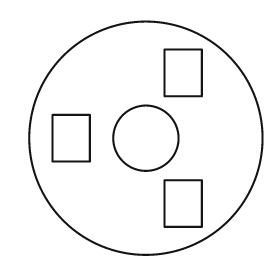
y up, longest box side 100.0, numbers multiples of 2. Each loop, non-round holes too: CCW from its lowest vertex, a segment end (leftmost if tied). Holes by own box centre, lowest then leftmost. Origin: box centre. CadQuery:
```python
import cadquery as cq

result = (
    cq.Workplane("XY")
    .moveTo(0.0, 0.0)
    .circle(50.0)
    .moveTo(8.0, -38.0)
    .lineTo(24.0, -38.0)
    .lineTo(24.0, -18.0)
    .lineTo(8.0, -18.0)
    .close()
    .moveTo(-40.0, -10.0)
    .lineTo(-24.0, -10.0)
    .lineTo(-24.0, 10.0)
    .lineTo(-40.0, 10.0)
    .close()
    .moveTo(0.0, 0.0)
    .circle(14.0)
    .moveTo(8.0, 18.0)
    .lineTo(24.0, 18.0)
    .lineTo(24.0, 38.0)
    .lineTo(8.0, 38.0)
    .close()
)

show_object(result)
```